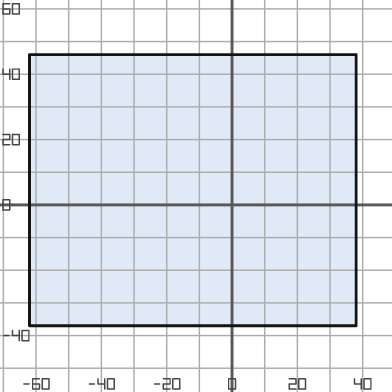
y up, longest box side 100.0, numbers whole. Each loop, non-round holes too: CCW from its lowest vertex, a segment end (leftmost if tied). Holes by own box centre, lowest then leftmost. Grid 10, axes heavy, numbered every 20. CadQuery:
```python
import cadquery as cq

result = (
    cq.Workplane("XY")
    .moveTo(-62.0, -37.0)
    .lineTo(38.0, -37.0)
    .lineTo(38.0, 46.0)
    .lineTo(-62.0, 46.0)
    .close()
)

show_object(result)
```